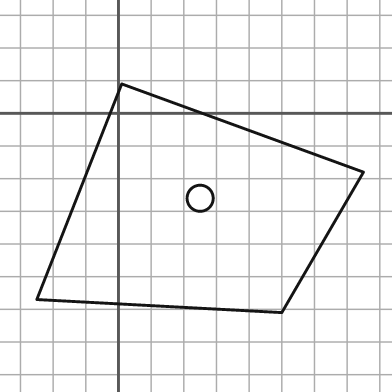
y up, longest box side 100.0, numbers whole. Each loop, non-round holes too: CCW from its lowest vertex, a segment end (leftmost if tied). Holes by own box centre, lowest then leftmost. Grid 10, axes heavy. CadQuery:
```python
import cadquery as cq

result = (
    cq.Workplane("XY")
    .moveTo(50.0, -61.0)
    .lineTo(75.0, -18.0)
    .lineTo(1.0, 9.0)
    .lineTo(-25.0, -57.0)
    .close()
    .moveTo(25.0, -26.0)
    .circle(4.0)
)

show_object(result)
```